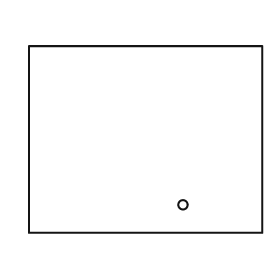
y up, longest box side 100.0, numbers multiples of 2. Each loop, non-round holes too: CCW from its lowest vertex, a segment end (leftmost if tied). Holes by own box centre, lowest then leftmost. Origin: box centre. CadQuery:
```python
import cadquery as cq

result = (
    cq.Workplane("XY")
    .moveTo(-50.0, -40.0)
    .lineTo(50.0, -40.0)
    .lineTo(50.0, 40.0)
    .lineTo(-50.0, 40.0)
    .close()
    .moveTo(16.0, -28.0)
    .circle(2.0)
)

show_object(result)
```